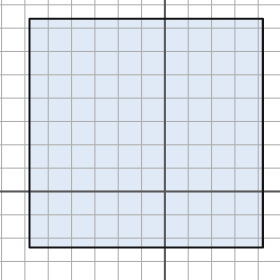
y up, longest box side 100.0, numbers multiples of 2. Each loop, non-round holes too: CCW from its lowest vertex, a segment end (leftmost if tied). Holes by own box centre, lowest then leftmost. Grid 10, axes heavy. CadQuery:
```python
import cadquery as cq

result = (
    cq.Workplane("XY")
    .moveTo(-58.0, -24.0)
    .lineTo(42.0, -24.0)
    .lineTo(42.0, 74.0)
    .lineTo(-58.0, 74.0)
    .close()
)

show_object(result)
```